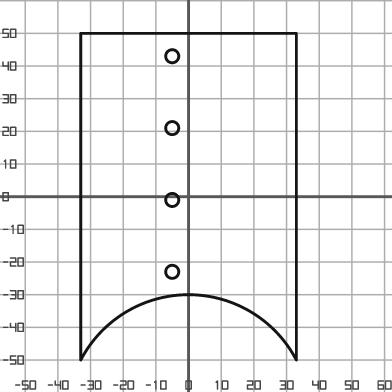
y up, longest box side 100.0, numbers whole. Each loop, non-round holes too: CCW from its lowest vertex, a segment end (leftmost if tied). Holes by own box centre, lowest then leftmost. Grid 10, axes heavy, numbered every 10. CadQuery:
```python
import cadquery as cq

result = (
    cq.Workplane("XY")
    .moveTo(-33.0, -50.0)
    .threePointArc((0.0, -30.0), (33.0, -50.0))
    .lineTo(33.0, 50.0)
    .lineTo(-33.0, 50.0)
    .close()
    .moveTo(-5.0, -23.0)
    .circle(2.0)
    .moveTo(-5.0, -1.0)
    .circle(2.0)
    .moveTo(-5.0, 21.0)
    .circle(2.0)
    .moveTo(-5.0, 43.0)
    .circle(2.0)
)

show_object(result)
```